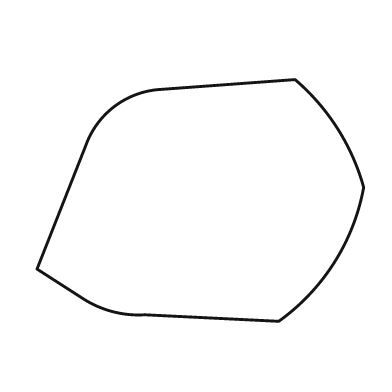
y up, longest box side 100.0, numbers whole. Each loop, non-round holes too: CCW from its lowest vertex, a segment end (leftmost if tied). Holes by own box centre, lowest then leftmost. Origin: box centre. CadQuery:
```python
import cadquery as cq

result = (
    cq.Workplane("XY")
    .moveTo(24.0, -37.0)
    .threePointArc((41.0, -19.0), (50.0, 4.0))
    .threePointArc((42.0, 22.0), (29.0, 37.0))
    .lineTo(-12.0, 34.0)
    .threePointArc((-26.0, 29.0), (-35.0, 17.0))
    .lineTo(-50.0, -21.0)
    .lineTo(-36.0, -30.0)
    .threePointArc((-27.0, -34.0), (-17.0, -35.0))
    .close()
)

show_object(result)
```